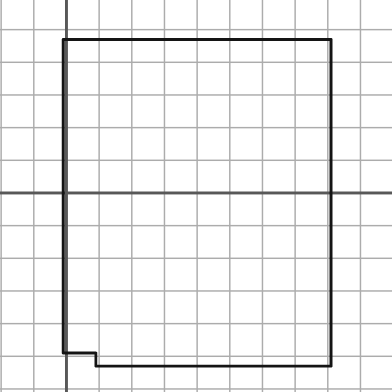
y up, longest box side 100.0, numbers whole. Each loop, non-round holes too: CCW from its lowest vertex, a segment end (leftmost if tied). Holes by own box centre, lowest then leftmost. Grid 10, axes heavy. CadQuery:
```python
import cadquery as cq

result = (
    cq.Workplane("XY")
    .moveTo(9.0, -53.0)
    .lineTo(81.0, -53.0)
    .lineTo(81.0, 47.0)
    .lineTo(-1.0, 47.0)
    .lineTo(-1.0, -49.0)
    .lineTo(9.0, -49.0)
    .close()
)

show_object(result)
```